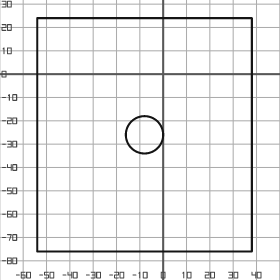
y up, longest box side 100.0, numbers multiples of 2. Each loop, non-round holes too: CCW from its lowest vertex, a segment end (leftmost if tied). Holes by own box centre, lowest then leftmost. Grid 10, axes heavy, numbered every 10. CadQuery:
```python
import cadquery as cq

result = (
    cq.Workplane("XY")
    .moveTo(-54.0, -76.0)
    .lineTo(38.0, -76.0)
    .lineTo(38.0, 24.0)
    .lineTo(-54.0, 24.0)
    .close()
    .moveTo(-8.0, -26.0)
    .circle(8.0)
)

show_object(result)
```